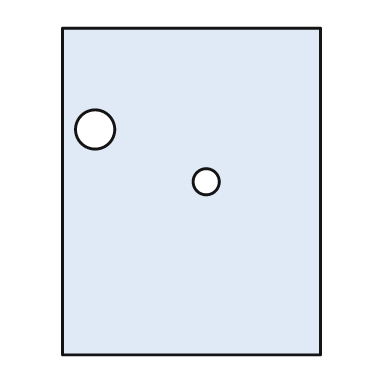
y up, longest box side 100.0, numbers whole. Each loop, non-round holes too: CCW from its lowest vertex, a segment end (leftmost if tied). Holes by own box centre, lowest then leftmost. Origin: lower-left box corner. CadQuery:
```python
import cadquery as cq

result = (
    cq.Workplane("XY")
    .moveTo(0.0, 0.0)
    .lineTo(79.0, 0.0)
    .lineTo(79.0, 100.0)
    .lineTo(0.0, 100.0)
    .close()
    .moveTo(44.0, 53.0)
    .circle(4.0)
    .moveTo(10.0, 69.0)
    .circle(6.0)
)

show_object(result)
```